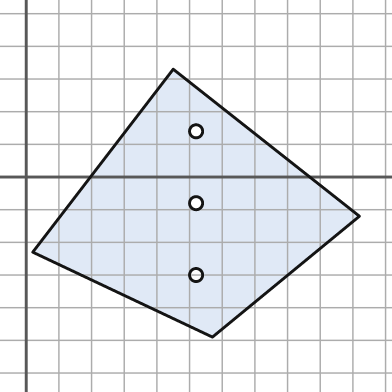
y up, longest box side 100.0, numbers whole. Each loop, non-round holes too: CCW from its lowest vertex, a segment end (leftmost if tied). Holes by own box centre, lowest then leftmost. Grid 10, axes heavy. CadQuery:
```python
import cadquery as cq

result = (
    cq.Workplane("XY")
    .moveTo(57.0, -49.0)
    .lineTo(102.0, -12.0)
    .lineTo(45.0, 33.0)
    .lineTo(2.0, -23.0)
    .close()
    .moveTo(52.0, -30.0)
    .circle(2.0)
    .moveTo(52.0, -8.0)
    .circle(2.0)
    .moveTo(52.0, 14.0)
    .circle(2.0)
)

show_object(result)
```